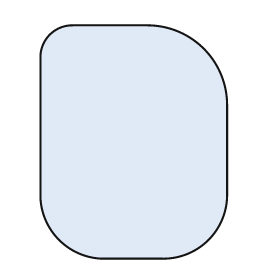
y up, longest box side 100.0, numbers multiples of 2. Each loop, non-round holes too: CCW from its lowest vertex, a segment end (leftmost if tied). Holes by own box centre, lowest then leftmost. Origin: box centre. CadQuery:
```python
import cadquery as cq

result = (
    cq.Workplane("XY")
    .moveTo(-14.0, -50.0)
    .lineTo(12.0, -50.0)
    .threePointArc((32.0, -42.0), (40.0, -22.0))
    .lineTo(40.0, 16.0)
    .threePointArc((30.0, 40.0), (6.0, 50.0))
    .lineTo(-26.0, 50.0)
    .threePointArc((-36.0, 46.0), (-40.0, 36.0))
    .lineTo(-40.0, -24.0)
    .threePointArc((-32.0, -42.0), (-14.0, -50.0))
    .close()
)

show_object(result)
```